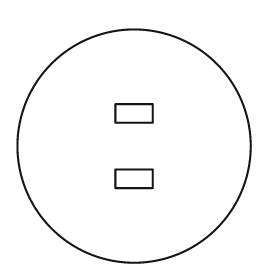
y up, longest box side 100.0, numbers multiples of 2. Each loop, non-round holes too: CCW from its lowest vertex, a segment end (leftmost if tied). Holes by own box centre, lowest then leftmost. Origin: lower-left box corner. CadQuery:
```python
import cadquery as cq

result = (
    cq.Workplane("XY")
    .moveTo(50.0, 50.0)
    .circle(50.0)
    .moveTo(42.0, 32.0)
    .lineTo(58.0, 32.0)
    .lineTo(58.0, 40.0)
    .lineTo(42.0, 40.0)
    .close()
    .moveTo(42.0, 60.0)
    .lineTo(58.0, 60.0)
    .lineTo(58.0, 68.0)
    .lineTo(42.0, 68.0)
    .close()
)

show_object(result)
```